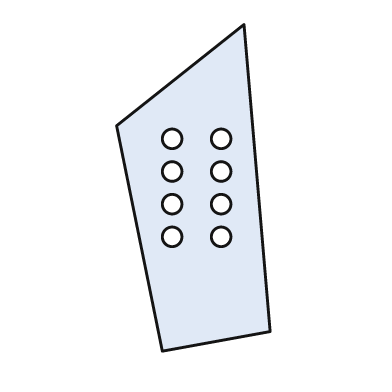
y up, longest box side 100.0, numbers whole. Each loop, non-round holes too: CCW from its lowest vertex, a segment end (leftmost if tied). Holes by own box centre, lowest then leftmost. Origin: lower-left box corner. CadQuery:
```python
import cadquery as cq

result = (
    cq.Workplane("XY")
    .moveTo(14.0, 0.0)
    .lineTo(47.0, 6.0)
    .lineTo(39.0, 100.0)
    .lineTo(0.0, 69.0)
    .close()
    .moveTo(17.0, 35.0)
    .circle(3.0)
    .moveTo(32.0, 35.0)
    .circle(3.0)
    .moveTo(17.0, 45.0)
    .circle(3.0)
    .moveTo(32.0, 45.0)
    .circle(3.0)
    .moveTo(17.0, 55.0)
    .circle(3.0)
    .moveTo(32.0, 55.0)
    .circle(3.0)
    .moveTo(17.0, 65.0)
    .circle(3.0)
    .moveTo(32.0, 65.0)
    .circle(3.0)
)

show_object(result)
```